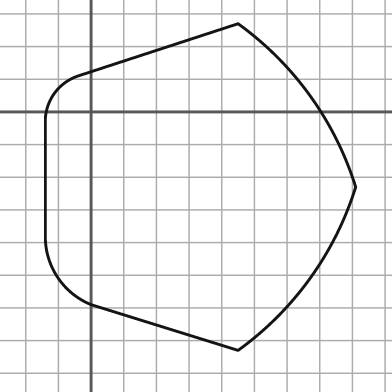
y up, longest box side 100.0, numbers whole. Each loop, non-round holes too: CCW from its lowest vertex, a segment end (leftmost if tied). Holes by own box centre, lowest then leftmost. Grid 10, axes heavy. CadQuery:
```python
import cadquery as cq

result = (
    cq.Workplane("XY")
    .moveTo(45.0, -73.0)
    .threePointArc((67.0, -51.0), (81.0, -23.0))
    .threePointArc((67.0, 5.0), (45.0, 27.0))
    .lineTo(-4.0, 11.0)
    .threePointArc((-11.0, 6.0), (-14.0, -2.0))
    .lineTo(-14.0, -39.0)
    .threePointArc((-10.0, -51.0), (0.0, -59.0))
    .close()
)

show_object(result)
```